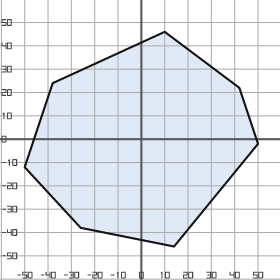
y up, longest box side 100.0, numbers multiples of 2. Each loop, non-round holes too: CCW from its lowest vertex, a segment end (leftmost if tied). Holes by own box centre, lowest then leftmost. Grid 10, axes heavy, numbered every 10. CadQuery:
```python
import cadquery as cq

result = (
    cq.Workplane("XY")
    .moveTo(14.0, -46.0)
    .lineTo(50.0, -2.0)
    .lineTo(42.0, 22.0)
    .lineTo(10.0, 46.0)
    .lineTo(-38.0, 24.0)
    .lineTo(-50.0, -12.0)
    .lineTo(-26.0, -38.0)
    .close()
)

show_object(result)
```